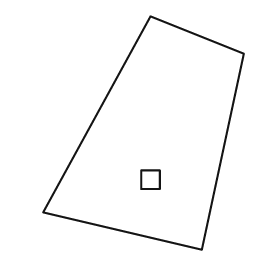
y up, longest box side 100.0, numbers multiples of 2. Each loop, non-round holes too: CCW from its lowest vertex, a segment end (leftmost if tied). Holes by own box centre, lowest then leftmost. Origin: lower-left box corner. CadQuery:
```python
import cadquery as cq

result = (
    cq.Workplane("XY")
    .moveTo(68.0, 0.0)
    .lineTo(86.0, 84.0)
    .lineTo(46.0, 100.0)
    .lineTo(0.0, 16.0)
    .close()
    .moveTo(42.0, 26.0)
    .lineTo(50.0, 26.0)
    .lineTo(50.0, 34.0)
    .lineTo(42.0, 34.0)
    .close()
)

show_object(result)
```